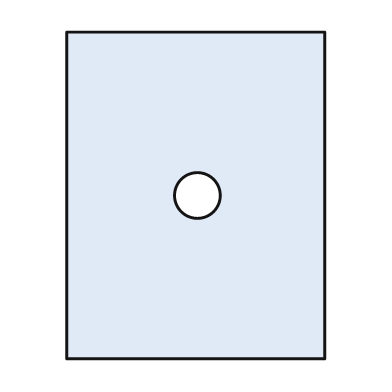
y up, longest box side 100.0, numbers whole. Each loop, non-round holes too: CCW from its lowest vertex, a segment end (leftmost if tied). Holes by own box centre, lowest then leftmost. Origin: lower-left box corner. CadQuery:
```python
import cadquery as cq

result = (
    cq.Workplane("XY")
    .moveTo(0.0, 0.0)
    .lineTo(79.0, 0.0)
    .lineTo(79.0, 100.0)
    .lineTo(0.0, 100.0)
    .close()
    .moveTo(40.0, 50.0)
    .circle(7.0)
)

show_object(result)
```